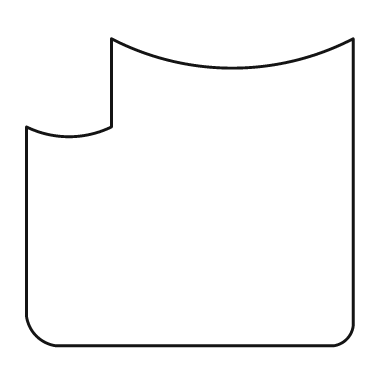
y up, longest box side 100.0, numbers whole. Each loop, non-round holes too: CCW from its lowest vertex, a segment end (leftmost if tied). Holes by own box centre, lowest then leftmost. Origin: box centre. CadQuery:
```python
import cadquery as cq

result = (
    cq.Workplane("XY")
    .moveTo(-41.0, -47.0)
    .lineTo(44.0, -47.0)
    .threePointArc((48.0, -45.0), (50.0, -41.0))
    .lineTo(50.0, 47.0)
    .threePointArc((13.0, 38.0), (-24.0, 47.0))
    .lineTo(-24.0, 20.0)
    .threePointArc((-37.0, 17.0), (-50.0, 20.0))
    .lineTo(-50.0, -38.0)
    .threePointArc((-47.0, -44.0), (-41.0, -47.0))
    .close()
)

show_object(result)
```